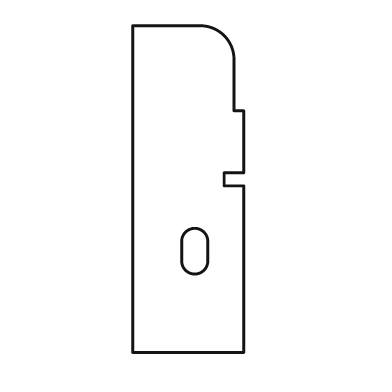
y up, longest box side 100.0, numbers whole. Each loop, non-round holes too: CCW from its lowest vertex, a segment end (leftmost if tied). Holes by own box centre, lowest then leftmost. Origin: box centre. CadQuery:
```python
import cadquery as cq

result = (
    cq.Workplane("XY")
    .moveTo(-17.0, -50.0)
    .lineTo(17.0, -50.0)
    .lineTo(17.0, 1.0)
    .lineTo(11.0, 1.0)
    .lineTo(11.0, 5.0)
    .lineTo(17.0, 5.0)
    .lineTo(17.0, 24.0)
    .lineTo(14.0, 24.0)
    .lineTo(14.0, 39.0)
    .threePointArc((11.0, 47.0), (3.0, 50.0))
    .lineTo(-17.0, 50.0)
    .close()
    .moveTo(-2.0, -22.0)
    .threePointArc((2.0, -26.0), (6.0, -22.0))
    .lineTo(6.0, -16.0)
    .threePointArc((2.0, -12.0), (-2.0, -16.0))
    .close()
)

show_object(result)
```